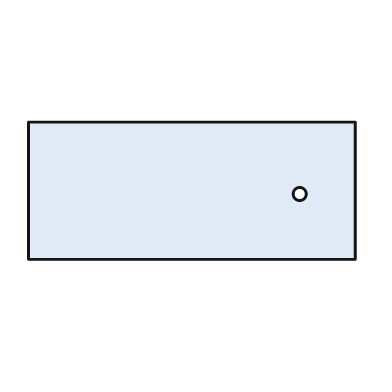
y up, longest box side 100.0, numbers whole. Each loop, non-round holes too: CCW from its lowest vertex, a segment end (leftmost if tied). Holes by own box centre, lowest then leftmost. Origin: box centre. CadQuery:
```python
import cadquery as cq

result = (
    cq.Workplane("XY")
    .moveTo(-50.0, -21.0)
    .lineTo(50.0, -21.0)
    .lineTo(50.0, 21.0)
    .lineTo(-50.0, 21.0)
    .close()
    .moveTo(33.0, -1.0)
    .circle(2.0)
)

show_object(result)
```